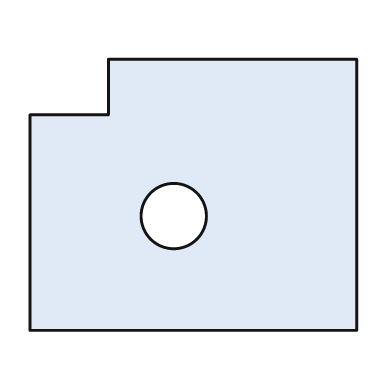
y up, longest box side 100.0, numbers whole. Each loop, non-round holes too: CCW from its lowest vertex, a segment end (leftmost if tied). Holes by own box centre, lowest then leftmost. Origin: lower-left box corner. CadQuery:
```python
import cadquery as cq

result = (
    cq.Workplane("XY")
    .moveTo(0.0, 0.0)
    .lineTo(100.0, 0.0)
    .lineTo(100.0, 83.0)
    .lineTo(24.0, 83.0)
    .lineTo(24.0, 66.0)
    .lineTo(0.0, 66.0)
    .close()
    .moveTo(44.0, 35.0)
    .circle(10.0)
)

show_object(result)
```